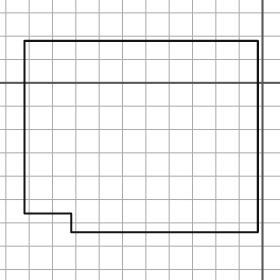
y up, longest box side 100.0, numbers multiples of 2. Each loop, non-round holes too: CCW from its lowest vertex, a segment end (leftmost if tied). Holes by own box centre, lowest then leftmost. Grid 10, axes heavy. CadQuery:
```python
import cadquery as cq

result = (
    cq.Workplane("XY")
    .moveTo(-82.0, -64.0)
    .lineTo(-2.0, -64.0)
    .lineTo(-2.0, 18.0)
    .lineTo(-102.0, 18.0)
    .lineTo(-102.0, -56.0)
    .lineTo(-82.0, -56.0)
    .close()
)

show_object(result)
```